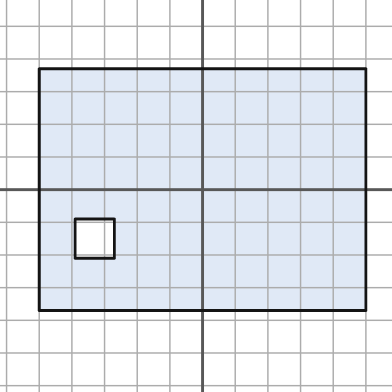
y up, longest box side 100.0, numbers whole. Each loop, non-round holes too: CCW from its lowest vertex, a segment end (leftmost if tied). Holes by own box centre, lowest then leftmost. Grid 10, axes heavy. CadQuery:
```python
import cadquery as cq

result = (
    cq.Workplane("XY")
    .moveTo(-50.0, -37.0)
    .lineTo(50.0, -37.0)
    .lineTo(50.0, 37.0)
    .lineTo(-50.0, 37.0)
    .close()
    .moveTo(-39.0, -21.0)
    .lineTo(-27.0, -21.0)
    .lineTo(-27.0, -9.0)
    .lineTo(-39.0, -9.0)
    .close()
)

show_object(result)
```